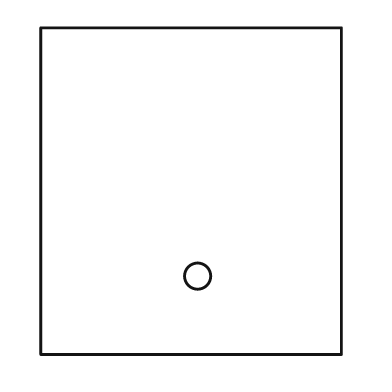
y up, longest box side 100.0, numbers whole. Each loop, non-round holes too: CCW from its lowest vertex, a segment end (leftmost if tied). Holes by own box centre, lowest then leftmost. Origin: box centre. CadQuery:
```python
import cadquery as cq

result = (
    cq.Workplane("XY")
    .moveTo(-46.0, -50.0)
    .lineTo(46.0, -50.0)
    .lineTo(46.0, 50.0)
    .lineTo(-46.0, 50.0)
    .close()
    .moveTo(2.0, -26.0)
    .circle(4.0)
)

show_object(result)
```